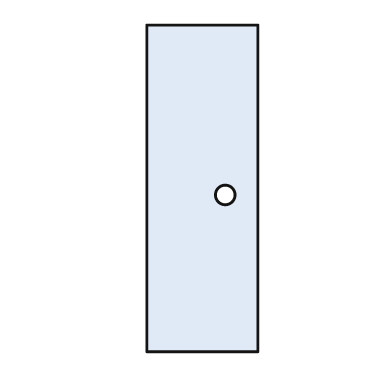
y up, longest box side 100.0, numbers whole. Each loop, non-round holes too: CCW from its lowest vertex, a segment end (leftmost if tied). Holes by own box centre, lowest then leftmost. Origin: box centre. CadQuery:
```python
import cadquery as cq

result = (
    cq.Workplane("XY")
    .moveTo(-17.0, -50.0)
    .lineTo(17.0, -50.0)
    .lineTo(17.0, 50.0)
    .lineTo(-17.0, 50.0)
    .close()
    .moveTo(7.0, -2.0)
    .circle(3.0)
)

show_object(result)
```